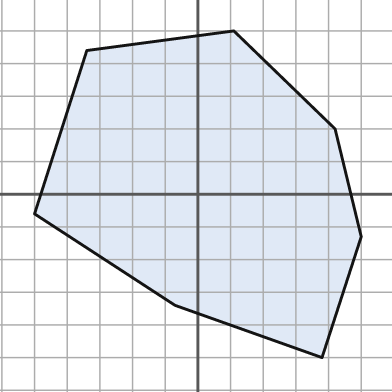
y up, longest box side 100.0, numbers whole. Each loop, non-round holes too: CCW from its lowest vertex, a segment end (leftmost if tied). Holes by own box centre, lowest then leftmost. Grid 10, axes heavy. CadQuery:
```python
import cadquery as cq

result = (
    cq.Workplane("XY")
    .moveTo(38.0, -50.0)
    .lineTo(50.0, -13.0)
    .lineTo(42.0, 20.0)
    .lineTo(11.0, 50.0)
    .lineTo(-34.0, 44.0)
    .lineTo(-50.0, -6.0)
    .lineTo(-7.0, -34.0)
    .close()
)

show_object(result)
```